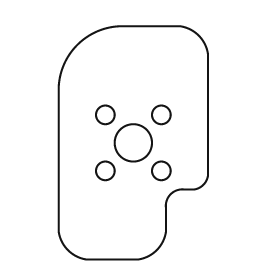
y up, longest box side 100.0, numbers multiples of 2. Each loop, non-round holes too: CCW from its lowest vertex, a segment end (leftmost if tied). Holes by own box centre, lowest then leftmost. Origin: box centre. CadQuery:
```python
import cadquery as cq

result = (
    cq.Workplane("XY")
    .moveTo(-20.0, -50.0)
    .lineTo(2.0, -50.0)
    .threePointArc((10.0, -46.0), (14.0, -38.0))
    .lineTo(14.0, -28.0)
    .threePointArc((16.0, -22.0), (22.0, -20.0))
    .lineTo(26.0, -20.0)
    .threePointArc((30.0, -18.0), (32.0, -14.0))
    .lineTo(32.0, 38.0)
    .threePointArc((28.0, 46.0), (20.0, 50.0))
    .lineTo(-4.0, 50.0)
    .threePointArc((-24.0, 42.0), (-32.0, 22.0))
    .lineTo(-32.0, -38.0)
    .threePointArc((-28.0, -46.0), (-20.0, -50.0))
    .close()
    .moveTo(-12.0, -12.0)
    .circle(4.0)
    .moveTo(12.0, -12.0)
    .circle(4.0)
    .moveTo(0.0, 0.0)
    .circle(8.0)
    .moveTo(-12.0, 12.0)
    .circle(4.0)
    .moveTo(12.0, 12.0)
    .circle(4.0)
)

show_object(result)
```